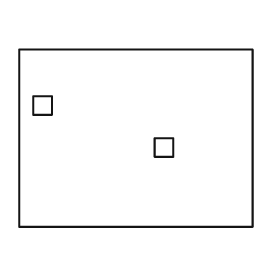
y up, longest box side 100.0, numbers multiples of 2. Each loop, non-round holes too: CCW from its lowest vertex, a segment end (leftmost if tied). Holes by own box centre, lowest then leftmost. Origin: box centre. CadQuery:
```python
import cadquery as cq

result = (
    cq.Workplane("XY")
    .moveTo(-50.0, -38.0)
    .lineTo(50.0, -38.0)
    .lineTo(50.0, 38.0)
    .lineTo(-50.0, 38.0)
    .close()
    .moveTo(8.0, -8.0)
    .lineTo(16.0, -8.0)
    .lineTo(16.0, 0.0)
    .lineTo(8.0, 0.0)
    .close()
    .moveTo(-44.0, 10.0)
    .lineTo(-36.0, 10.0)
    .lineTo(-36.0, 18.0)
    .lineTo(-44.0, 18.0)
    .close()
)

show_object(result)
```